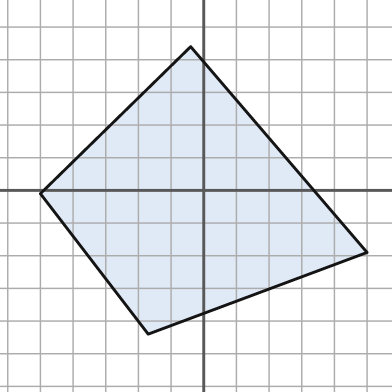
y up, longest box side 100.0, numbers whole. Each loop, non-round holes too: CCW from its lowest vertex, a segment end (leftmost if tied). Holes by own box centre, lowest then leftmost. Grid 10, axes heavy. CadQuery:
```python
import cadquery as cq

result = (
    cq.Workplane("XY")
    .moveTo(-17.0, -44.0)
    .lineTo(50.0, -19.0)
    .lineTo(-4.0, 44.0)
    .lineTo(-50.0, -1.0)
    .close()
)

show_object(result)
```